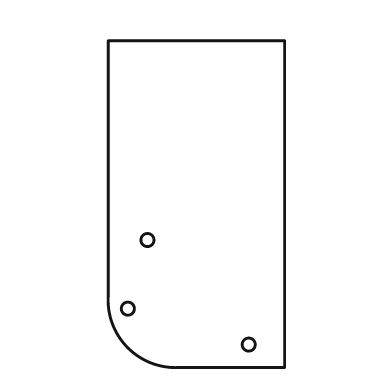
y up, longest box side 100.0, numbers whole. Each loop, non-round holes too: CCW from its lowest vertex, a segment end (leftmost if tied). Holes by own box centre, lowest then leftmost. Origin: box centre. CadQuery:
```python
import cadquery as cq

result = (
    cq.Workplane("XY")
    .moveTo(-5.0, -50.0)
    .lineTo(27.0, -50.0)
    .lineTo(27.0, 50.0)
    .lineTo(-27.0, 50.0)
    .lineTo(-27.0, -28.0)
    .threePointArc((-21.0, -44.0), (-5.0, -50.0))
    .close()
    .moveTo(16.0, -43.0)
    .circle(2.0)
    .moveTo(-21.0, -32.0)
    .circle(2.0)
    .moveTo(-15.0, -11.0)
    .circle(2.0)
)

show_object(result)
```